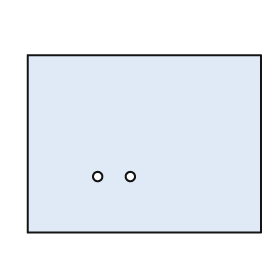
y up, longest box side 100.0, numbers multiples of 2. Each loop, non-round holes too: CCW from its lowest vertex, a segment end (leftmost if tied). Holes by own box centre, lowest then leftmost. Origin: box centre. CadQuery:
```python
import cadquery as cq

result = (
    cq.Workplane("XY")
    .moveTo(-50.0, -38.0)
    .lineTo(50.0, -38.0)
    .lineTo(50.0, 38.0)
    .lineTo(-50.0, 38.0)
    .close()
    .moveTo(-20.0, -14.0)
    .circle(2.0)
    .moveTo(-6.0, -14.0)
    .circle(2.0)
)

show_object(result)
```